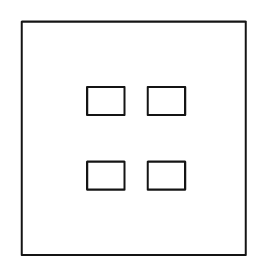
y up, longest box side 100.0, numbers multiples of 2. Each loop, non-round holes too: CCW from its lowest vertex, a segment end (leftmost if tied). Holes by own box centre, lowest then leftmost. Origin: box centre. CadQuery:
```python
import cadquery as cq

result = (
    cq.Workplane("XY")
    .moveTo(-48.0, -50.0)
    .lineTo(48.0, -50.0)
    .lineTo(48.0, 50.0)
    .lineTo(-48.0, 50.0)
    .close()
    .moveTo(-20.0, -22.0)
    .lineTo(-4.0, -22.0)
    .lineTo(-4.0, -10.0)
    .lineTo(-20.0, -10.0)
    .close()
    .moveTo(6.0, -22.0)
    .lineTo(22.0, -22.0)
    .lineTo(22.0, -10.0)
    .lineTo(6.0, -10.0)
    .close()
    .moveTo(-20.0, 10.0)
    .lineTo(-4.0, 10.0)
    .lineTo(-4.0, 22.0)
    .lineTo(-20.0, 22.0)
    .close()
    .moveTo(6.0, 10.0)
    .lineTo(22.0, 10.0)
    .lineTo(22.0, 22.0)
    .lineTo(6.0, 22.0)
    .close()
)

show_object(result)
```